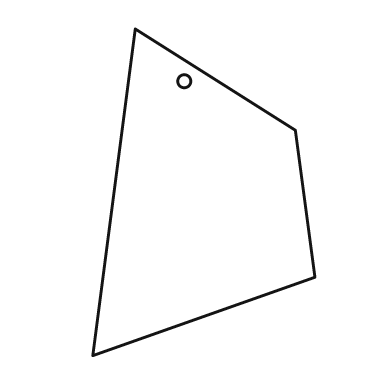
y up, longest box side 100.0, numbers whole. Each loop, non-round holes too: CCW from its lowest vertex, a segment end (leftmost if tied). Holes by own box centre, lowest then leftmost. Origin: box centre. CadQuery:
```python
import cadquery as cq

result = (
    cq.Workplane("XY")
    .moveTo(-34.0, -50.0)
    .lineTo(34.0, -26.0)
    .lineTo(28.0, 19.0)
    .lineTo(-21.0, 50.0)
    .close()
    .moveTo(-6.0, 34.0)
    .circle(2.0)
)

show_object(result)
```